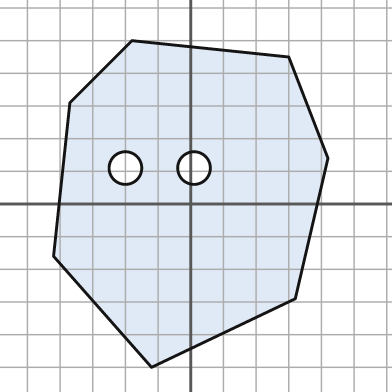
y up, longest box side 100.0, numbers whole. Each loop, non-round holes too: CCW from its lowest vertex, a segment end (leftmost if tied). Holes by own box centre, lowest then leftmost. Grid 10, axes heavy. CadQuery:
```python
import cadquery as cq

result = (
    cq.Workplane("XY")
    .moveTo(-12.0, -50.0)
    .lineTo(32.0, -29.0)
    .lineTo(42.0, 14.0)
    .lineTo(30.0, 45.0)
    .lineTo(-18.0, 50.0)
    .lineTo(-37.0, 31.0)
    .lineTo(-42.0, -16.0)
    .close()
    .moveTo(-20.0, 11.0)
    .circle(5.0)
    .moveTo(1.0, 11.0)
    .circle(5.0)
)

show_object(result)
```